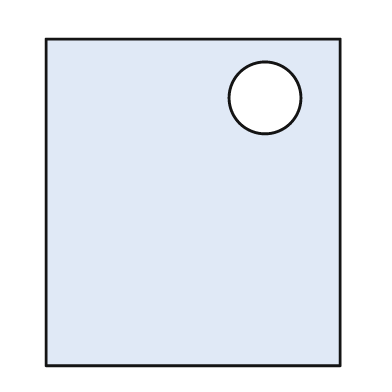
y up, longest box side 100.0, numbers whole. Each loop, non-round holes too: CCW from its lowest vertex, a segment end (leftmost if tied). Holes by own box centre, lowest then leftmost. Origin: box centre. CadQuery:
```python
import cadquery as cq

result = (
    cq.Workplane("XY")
    .moveTo(-45.0, -50.0)
    .lineTo(45.0, -50.0)
    .lineTo(45.0, 50.0)
    .lineTo(-45.0, 50.0)
    .close()
    .moveTo(22.0, 32.0)
    .circle(11.0)
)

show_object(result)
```